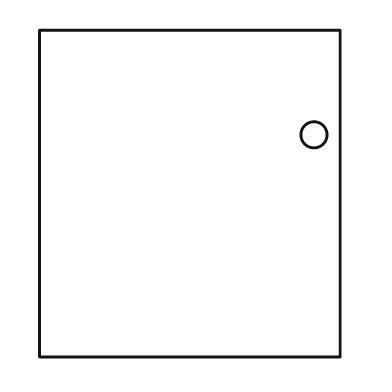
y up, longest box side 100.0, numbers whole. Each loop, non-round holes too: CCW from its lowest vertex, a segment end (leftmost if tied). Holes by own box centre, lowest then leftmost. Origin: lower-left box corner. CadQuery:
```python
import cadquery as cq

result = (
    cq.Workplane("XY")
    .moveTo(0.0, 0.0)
    .lineTo(92.0, 0.0)
    .lineTo(92.0, 100.0)
    .lineTo(0.0, 100.0)
    .close()
    .moveTo(84.0, 68.0)
    .circle(4.0)
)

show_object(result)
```